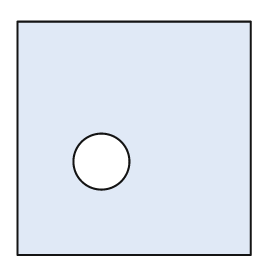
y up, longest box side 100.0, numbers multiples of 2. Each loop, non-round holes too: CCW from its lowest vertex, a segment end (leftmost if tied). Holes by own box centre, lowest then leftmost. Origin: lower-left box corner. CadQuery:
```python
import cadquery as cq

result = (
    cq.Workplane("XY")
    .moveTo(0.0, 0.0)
    .lineTo(100.0, 0.0)
    .lineTo(100.0, 100.0)
    .lineTo(0.0, 100.0)
    .close()
    .moveTo(36.0, 40.0)
    .circle(12.0)
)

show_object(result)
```